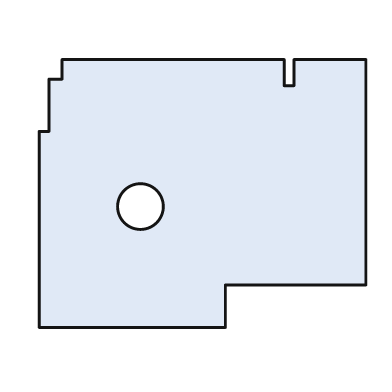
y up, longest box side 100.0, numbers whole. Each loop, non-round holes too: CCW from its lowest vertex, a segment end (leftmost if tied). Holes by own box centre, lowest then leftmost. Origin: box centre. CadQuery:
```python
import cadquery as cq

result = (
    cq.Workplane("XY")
    .moveTo(-50.0, -41.0)
    .lineTo(7.0, -41.0)
    .lineTo(7.0, -28.0)
    .lineTo(50.0, -28.0)
    .lineTo(50.0, 41.0)
    .lineTo(28.0, 41.0)
    .lineTo(28.0, 33.0)
    .lineTo(25.0, 33.0)
    .lineTo(25.0, 41.0)
    .lineTo(-43.0, 41.0)
    .lineTo(-43.0, 35.0)
    .lineTo(-47.0, 35.0)
    .lineTo(-47.0, 19.0)
    .lineTo(-50.0, 19.0)
    .close()
    .moveTo(-19.0, -4.0)
    .circle(7.0)
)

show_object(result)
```